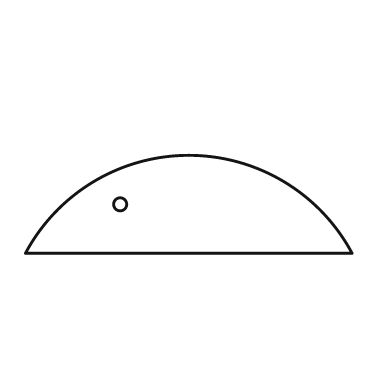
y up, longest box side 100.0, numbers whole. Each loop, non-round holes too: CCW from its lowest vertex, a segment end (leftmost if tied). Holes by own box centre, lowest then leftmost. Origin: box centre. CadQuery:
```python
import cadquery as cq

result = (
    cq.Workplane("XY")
    .moveTo(-50.0, -15.0)
    .lineTo(50.0, -15.0)
    .threePointArc((0.0, 15.0), (-50.0, -15.0))
    .close()
    .moveTo(-21.0, 0.0)
    .circle(2.0)
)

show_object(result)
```